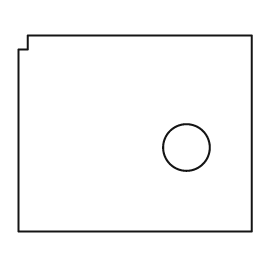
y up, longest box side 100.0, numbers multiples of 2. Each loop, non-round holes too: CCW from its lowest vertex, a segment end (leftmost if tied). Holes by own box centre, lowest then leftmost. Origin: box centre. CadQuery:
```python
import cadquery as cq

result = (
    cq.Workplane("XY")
    .moveTo(-50.0, -42.0)
    .lineTo(50.0, -42.0)
    .lineTo(50.0, 42.0)
    .lineTo(-46.0, 42.0)
    .lineTo(-46.0, 36.0)
    .lineTo(-50.0, 36.0)
    .close()
    .moveTo(22.0, -6.0)
    .circle(10.0)
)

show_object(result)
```